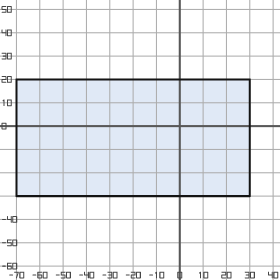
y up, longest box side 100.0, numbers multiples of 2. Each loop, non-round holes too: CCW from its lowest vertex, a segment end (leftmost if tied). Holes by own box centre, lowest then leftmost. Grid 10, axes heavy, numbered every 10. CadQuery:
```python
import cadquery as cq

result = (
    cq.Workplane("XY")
    .moveTo(-70.0, -30.0)
    .lineTo(30.0, -30.0)
    .lineTo(30.0, 20.0)
    .lineTo(-70.0, 20.0)
    .close()
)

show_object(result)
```